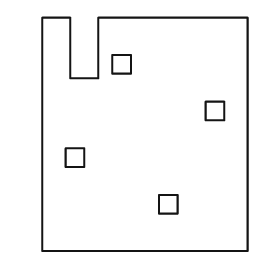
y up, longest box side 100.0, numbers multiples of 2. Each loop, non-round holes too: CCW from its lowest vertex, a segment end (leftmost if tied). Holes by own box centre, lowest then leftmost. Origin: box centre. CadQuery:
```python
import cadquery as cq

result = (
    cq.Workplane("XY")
    .moveTo(-44.0, -50.0)
    .lineTo(44.0, -50.0)
    .lineTo(44.0, 50.0)
    .lineTo(-20.0, 50.0)
    .lineTo(-20.0, 24.0)
    .lineTo(-32.0, 24.0)
    .lineTo(-32.0, 50.0)
    .lineTo(-44.0, 50.0)
    .close()
    .moveTo(6.0, -34.0)
    .lineTo(14.0, -34.0)
    .lineTo(14.0, -26.0)
    .lineTo(6.0, -26.0)
    .close()
    .moveTo(-34.0, -14.0)
    .lineTo(-26.0, -14.0)
    .lineTo(-26.0, -6.0)
    .lineTo(-34.0, -6.0)
    .close()
    .moveTo(26.0, 6.0)
    .lineTo(34.0, 6.0)
    .lineTo(34.0, 14.0)
    .lineTo(26.0, 14.0)
    .close()
    .moveTo(-14.0, 26.0)
    .lineTo(-6.0, 26.0)
    .lineTo(-6.0, 34.0)
    .lineTo(-14.0, 34.0)
    .close()
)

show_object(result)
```